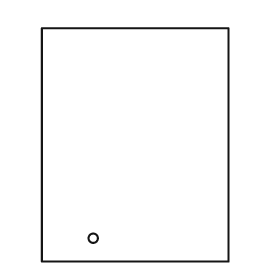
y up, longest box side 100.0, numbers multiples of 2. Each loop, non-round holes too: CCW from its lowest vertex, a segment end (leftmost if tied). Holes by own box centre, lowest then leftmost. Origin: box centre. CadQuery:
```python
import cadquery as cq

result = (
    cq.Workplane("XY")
    .moveTo(-40.0, -50.0)
    .lineTo(40.0, -50.0)
    .lineTo(40.0, 50.0)
    .lineTo(-40.0, 50.0)
    .close()
    .moveTo(-18.0, -40.0)
    .circle(2.0)
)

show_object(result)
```